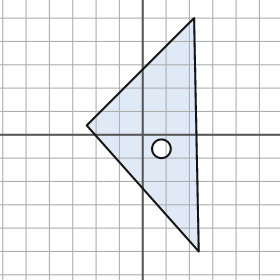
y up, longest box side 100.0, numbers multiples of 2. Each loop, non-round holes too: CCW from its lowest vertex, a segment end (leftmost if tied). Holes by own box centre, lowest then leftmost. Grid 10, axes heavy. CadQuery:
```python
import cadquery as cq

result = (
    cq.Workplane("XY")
    .moveTo(24.0, -50.0)
    .lineTo(22.0, 50.0)
    .lineTo(-24.0, 4.0)
    .close()
    .moveTo(8.0, -6.0)
    .circle(4.0)
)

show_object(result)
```